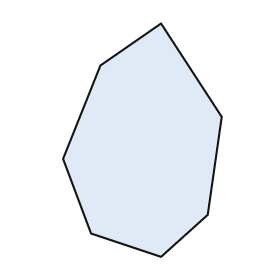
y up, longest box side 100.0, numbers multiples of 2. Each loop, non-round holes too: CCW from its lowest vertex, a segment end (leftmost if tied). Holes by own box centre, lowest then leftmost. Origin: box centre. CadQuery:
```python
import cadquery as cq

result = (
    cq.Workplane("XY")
    .moveTo(8.0, -50.0)
    .lineTo(28.0, -32.0)
    .lineTo(34.0, 10.0)
    .lineTo(8.0, 50.0)
    .lineTo(-18.0, 32.0)
    .lineTo(-34.0, -8.0)
    .lineTo(-22.0, -40.0)
    .close()
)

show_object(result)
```